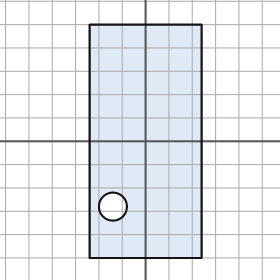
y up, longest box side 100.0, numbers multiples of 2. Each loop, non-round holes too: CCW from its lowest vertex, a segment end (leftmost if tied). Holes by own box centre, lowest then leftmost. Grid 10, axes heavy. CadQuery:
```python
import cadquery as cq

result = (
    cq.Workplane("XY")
    .moveTo(-24.0, -50.0)
    .lineTo(24.0, -50.0)
    .lineTo(24.0, 50.0)
    .lineTo(-24.0, 50.0)
    .close()
    .moveTo(-14.0, -28.0)
    .circle(6.0)
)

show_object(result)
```